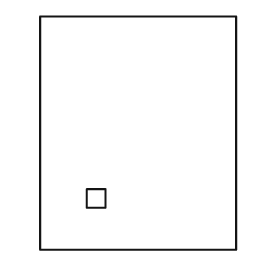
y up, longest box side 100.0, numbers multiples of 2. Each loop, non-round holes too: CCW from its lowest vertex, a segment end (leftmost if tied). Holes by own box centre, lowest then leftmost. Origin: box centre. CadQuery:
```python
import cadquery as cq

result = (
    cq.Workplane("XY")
    .moveTo(-42.0, -50.0)
    .lineTo(42.0, -50.0)
    .lineTo(42.0, 50.0)
    .lineTo(-42.0, 50.0)
    .close()
    .moveTo(-22.0, -32.0)
    .lineTo(-14.0, -32.0)
    .lineTo(-14.0, -24.0)
    .lineTo(-22.0, -24.0)
    .close()
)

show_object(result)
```